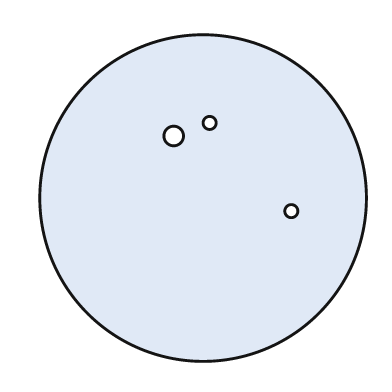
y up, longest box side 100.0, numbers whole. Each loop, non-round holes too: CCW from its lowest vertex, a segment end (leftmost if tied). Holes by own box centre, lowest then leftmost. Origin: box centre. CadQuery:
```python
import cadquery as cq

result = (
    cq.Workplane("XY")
    .moveTo(0.0, 0.0)
    .circle(50.0)
    .moveTo(27.0, -4.0)
    .circle(2.0)
    .moveTo(-9.0, 19.0)
    .circle(3.0)
    .moveTo(2.0, 23.0)
    .circle(2.0)
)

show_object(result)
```